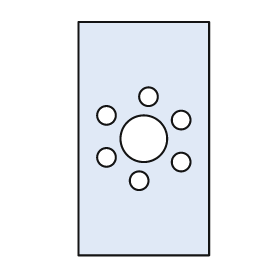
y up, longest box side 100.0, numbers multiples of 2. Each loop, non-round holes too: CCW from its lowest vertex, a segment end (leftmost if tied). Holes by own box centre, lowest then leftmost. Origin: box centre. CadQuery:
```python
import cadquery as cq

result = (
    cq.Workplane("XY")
    .moveTo(-28.0, -50.0)
    .lineTo(28.0, -50.0)
    .lineTo(28.0, 50.0)
    .lineTo(-28.0, 50.0)
    .close()
    .moveTo(-2.0, -18.0)
    .circle(4.0)
    .moveTo(16.0, -10.0)
    .circle(4.0)
    .moveTo(-16.0, -8.0)
    .circle(4.0)
    .moveTo(0.0, 0.0)
    .circle(10.0)
    .moveTo(16.0, 8.0)
    .circle(4.0)
    .moveTo(-16.0, 10.0)
    .circle(4.0)
    .moveTo(2.0, 18.0)
    .circle(4.0)
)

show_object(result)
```